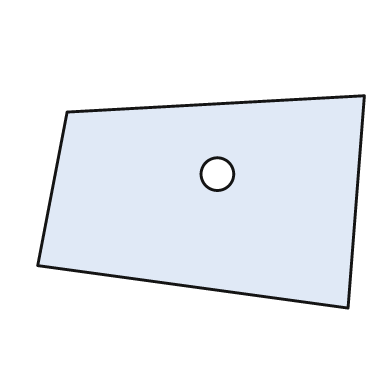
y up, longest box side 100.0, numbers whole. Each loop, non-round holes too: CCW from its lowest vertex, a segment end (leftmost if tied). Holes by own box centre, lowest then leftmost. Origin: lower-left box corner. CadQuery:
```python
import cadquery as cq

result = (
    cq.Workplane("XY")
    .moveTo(95.0, 0.0)
    .lineTo(100.0, 65.0)
    .lineTo(9.0, 60.0)
    .lineTo(0.0, 13.0)
    .close()
    .moveTo(55.0, 41.0)
    .circle(5.0)
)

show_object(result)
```